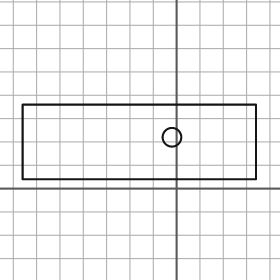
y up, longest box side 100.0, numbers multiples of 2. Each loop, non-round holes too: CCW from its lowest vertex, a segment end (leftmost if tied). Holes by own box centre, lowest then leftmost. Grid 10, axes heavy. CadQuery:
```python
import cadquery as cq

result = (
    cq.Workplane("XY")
    .moveTo(-66.0, 4.0)
    .lineTo(34.0, 4.0)
    .lineTo(34.0, 36.0)
    .lineTo(-66.0, 36.0)
    .close()
    .moveTo(-2.0, 22.0)
    .circle(4.0)
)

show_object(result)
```